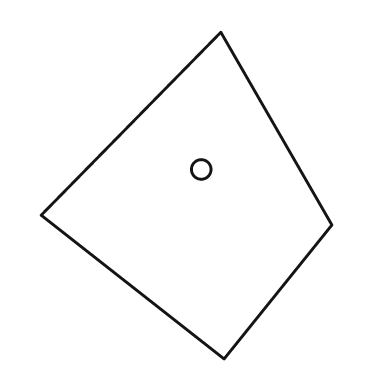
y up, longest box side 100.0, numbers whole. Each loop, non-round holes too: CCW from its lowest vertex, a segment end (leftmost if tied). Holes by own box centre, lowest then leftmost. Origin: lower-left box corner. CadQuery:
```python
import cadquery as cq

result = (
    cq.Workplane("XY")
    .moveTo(56.0, 0.0)
    .lineTo(89.0, 41.0)
    .lineTo(55.0, 100.0)
    .lineTo(0.0, 44.0)
    .close()
    .moveTo(49.0, 58.0)
    .circle(3.0)
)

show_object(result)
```